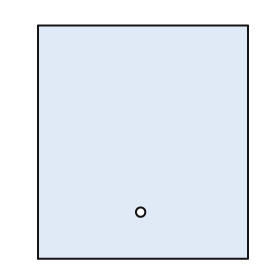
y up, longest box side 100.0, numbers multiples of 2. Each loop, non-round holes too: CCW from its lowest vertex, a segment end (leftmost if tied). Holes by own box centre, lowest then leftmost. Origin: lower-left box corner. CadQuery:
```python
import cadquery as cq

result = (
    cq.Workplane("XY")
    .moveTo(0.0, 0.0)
    .lineTo(90.0, 0.0)
    .lineTo(90.0, 100.0)
    .lineTo(0.0, 100.0)
    .close()
    .moveTo(44.0, 20.0)
    .circle(2.0)
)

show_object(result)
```